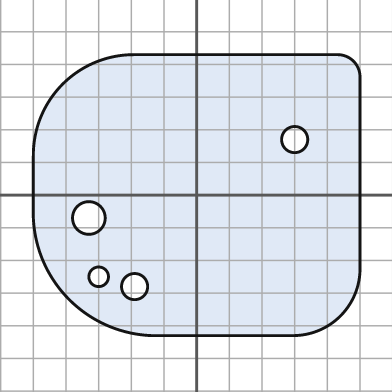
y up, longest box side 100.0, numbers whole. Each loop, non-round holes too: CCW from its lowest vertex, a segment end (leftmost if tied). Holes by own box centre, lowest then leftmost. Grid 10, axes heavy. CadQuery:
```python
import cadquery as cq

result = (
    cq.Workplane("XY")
    .moveTo(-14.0, -43.0)
    .lineTo(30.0, -43.0)
    .threePointArc((44.0, -37.0), (50.0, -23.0))
    .lineTo(50.0, 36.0)
    .threePointArc((48.0, 41.0), (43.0, 43.0))
    .lineTo(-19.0, 43.0)
    .threePointArc((-41.0, 34.0), (-50.0, 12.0))
    .lineTo(-50.0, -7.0)
    .threePointArc((-39.0, -32.0), (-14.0, -43.0))
    .close()
    .moveTo(-19.0, -28.0)
    .circle(4.0)
    .moveTo(-30.0, -25.0)
    .circle(3.0)
    .moveTo(-33.0, -7.0)
    .circle(5.0)
    .moveTo(30.0, 17.0)
    .circle(4.0)
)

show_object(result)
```